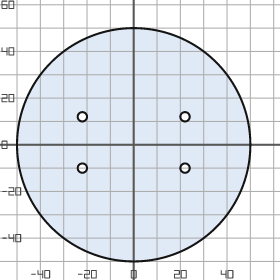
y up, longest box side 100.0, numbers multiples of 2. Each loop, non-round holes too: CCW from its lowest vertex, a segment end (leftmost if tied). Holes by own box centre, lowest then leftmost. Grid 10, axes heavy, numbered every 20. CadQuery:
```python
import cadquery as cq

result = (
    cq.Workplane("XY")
    .moveTo(0.0, 0.0)
    .circle(50.0)
    .moveTo(-22.0, -10.0)
    .circle(2.0)
    .moveTo(22.0, -10.0)
    .circle(2.0)
    .moveTo(-22.0, 12.0)
    .circle(2.0)
    .moveTo(22.0, 12.0)
    .circle(2.0)
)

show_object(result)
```